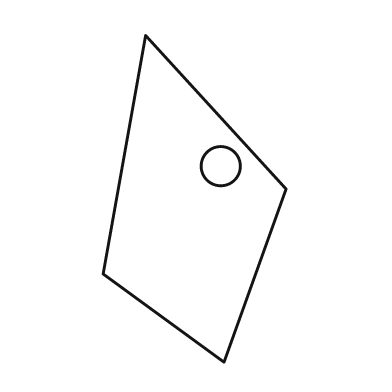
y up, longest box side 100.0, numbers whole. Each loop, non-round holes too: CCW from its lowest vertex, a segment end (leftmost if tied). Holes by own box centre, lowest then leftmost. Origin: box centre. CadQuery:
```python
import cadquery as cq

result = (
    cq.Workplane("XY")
    .moveTo(9.0, -50.0)
    .lineTo(28.0, 3.0)
    .lineTo(-15.0, 50.0)
    .lineTo(-28.0, -23.0)
    .close()
    .moveTo(8.0, 10.0)
    .circle(6.0)
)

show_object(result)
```